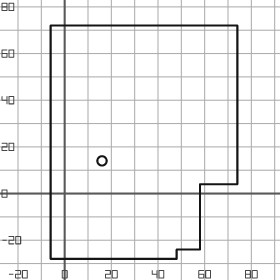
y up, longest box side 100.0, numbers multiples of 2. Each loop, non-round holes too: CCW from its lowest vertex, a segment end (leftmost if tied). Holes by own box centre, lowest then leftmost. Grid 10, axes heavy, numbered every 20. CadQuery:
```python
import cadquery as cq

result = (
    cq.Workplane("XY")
    .moveTo(-6.0, -28.0)
    .lineTo(48.0, -28.0)
    .lineTo(48.0, -24.0)
    .lineTo(58.0, -24.0)
    .lineTo(58.0, 4.0)
    .lineTo(74.0, 4.0)
    .lineTo(74.0, 72.0)
    .lineTo(-6.0, 72.0)
    .close()
    .moveTo(16.0, 14.0)
    .circle(2.0)
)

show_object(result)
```